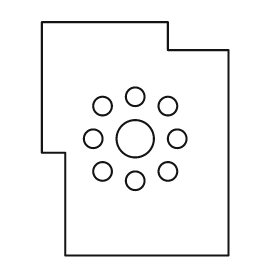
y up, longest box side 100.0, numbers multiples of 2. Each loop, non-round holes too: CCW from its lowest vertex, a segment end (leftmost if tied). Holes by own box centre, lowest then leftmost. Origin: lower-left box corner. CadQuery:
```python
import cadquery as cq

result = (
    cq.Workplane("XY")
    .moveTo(10.0, 0.0)
    .lineTo(80.0, 0.0)
    .lineTo(80.0, 88.0)
    .lineTo(54.0, 88.0)
    .lineTo(54.0, 100.0)
    .lineTo(0.0, 100.0)
    .lineTo(0.0, 44.0)
    .lineTo(10.0, 44.0)
    .close()
    .moveTo(40.0, 32.0)
    .circle(4.0)
    .moveTo(26.0, 36.0)
    .circle(4.0)
    .moveTo(54.0, 36.0)
    .circle(4.0)
    .moveTo(22.0, 50.0)
    .circle(4.0)
    .moveTo(40.0, 50.0)
    .circle(8.0)
    .moveTo(58.0, 50.0)
    .circle(4.0)
    .moveTo(26.0, 64.0)
    .circle(4.0)
    .moveTo(54.0, 64.0)
    .circle(4.0)
    .moveTo(40.0, 68.0)
    .circle(4.0)
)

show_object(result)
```